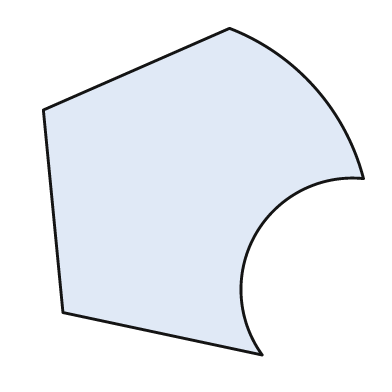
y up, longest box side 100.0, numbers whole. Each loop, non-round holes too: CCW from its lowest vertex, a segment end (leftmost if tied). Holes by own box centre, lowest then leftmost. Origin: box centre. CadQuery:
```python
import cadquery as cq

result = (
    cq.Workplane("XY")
    .moveTo(18.0, -50.0)
    .threePointArc((16.0, -13.0), (49.0, 4.0))
    .threePointArc((34.0, 32.0), (8.0, 50.0))
    .lineTo(-49.0, 25.0)
    .lineTo(-43.0, -37.0)
    .close()
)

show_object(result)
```